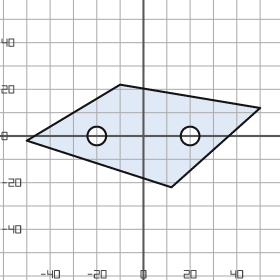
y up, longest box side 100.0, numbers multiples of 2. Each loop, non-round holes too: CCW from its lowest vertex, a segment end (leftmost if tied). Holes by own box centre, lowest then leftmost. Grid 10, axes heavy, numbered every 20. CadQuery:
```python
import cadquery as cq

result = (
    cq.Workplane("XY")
    .moveTo(12.0, -22.0)
    .lineTo(50.0, 12.0)
    .lineTo(-10.0, 22.0)
    .lineTo(-50.0, -2.0)
    .close()
    .moveTo(-20.0, 0.0)
    .circle(4.0)
    .moveTo(20.0, 0.0)
    .circle(4.0)
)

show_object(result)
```